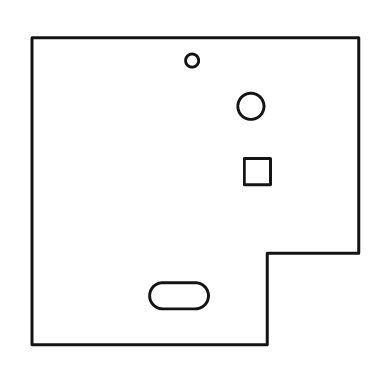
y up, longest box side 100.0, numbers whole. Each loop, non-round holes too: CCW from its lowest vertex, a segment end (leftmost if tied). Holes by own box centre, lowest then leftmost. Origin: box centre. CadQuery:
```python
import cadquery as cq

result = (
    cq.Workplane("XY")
    .moveTo(-50.0, -47.0)
    .lineTo(22.0, -47.0)
    .lineTo(22.0, -19.0)
    .lineTo(50.0, -19.0)
    .lineTo(50.0, 47.0)
    .lineTo(-50.0, 47.0)
    .close()
    .moveTo(-10.0, -36.0)
    .lineTo(0.0, -36.0)
    .threePointArc((4.0, -32.0), (0.0, -28.0))
    .lineTo(-10.0, -28.0)
    .threePointArc((-14.0, -32.0), (-10.0, -36.0))
    .close()
    .moveTo(15.0, 2.0)
    .lineTo(23.0, 2.0)
    .lineTo(23.0, 10.0)
    .lineTo(15.0, 10.0)
    .close()
    .moveTo(17.0, 26.0)
    .circle(4.0)
    .moveTo(-1.0, 40.0)
    .circle(2.0)
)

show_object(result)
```